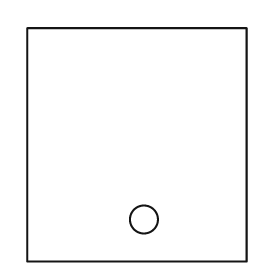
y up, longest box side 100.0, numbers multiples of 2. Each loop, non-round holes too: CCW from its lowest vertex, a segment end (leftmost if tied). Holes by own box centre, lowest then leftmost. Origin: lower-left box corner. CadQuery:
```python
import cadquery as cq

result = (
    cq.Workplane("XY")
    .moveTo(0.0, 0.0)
    .lineTo(94.0, 0.0)
    .lineTo(94.0, 100.0)
    .lineTo(0.0, 100.0)
    .close()
    .moveTo(50.0, 18.0)
    .circle(6.0)
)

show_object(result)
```